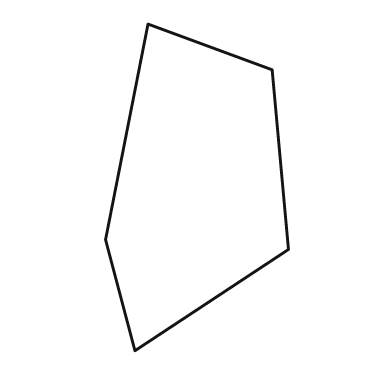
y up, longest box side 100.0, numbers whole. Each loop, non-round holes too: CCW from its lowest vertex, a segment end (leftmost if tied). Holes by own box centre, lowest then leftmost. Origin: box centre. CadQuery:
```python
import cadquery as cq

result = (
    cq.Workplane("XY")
    .moveTo(-19.0, -50.0)
    .lineTo(28.0, -19.0)
    .lineTo(23.0, 36.0)
    .lineTo(-15.0, 50.0)
    .lineTo(-28.0, -16.0)
    .close()
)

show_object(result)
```